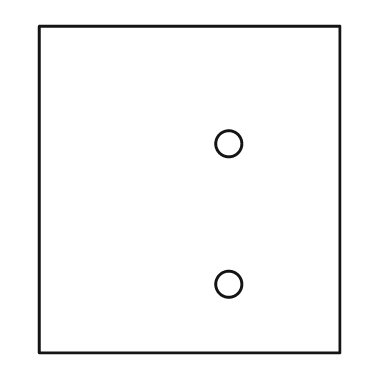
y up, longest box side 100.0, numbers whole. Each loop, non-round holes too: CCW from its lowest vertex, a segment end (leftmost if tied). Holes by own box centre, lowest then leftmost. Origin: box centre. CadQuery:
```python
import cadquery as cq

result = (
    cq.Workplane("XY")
    .moveTo(-46.0, -50.0)
    .lineTo(46.0, -50.0)
    .lineTo(46.0, 50.0)
    .lineTo(-46.0, 50.0)
    .close()
    .moveTo(12.0, -29.0)
    .circle(4.0)
    .moveTo(12.0, 14.0)
    .circle(4.0)
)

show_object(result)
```